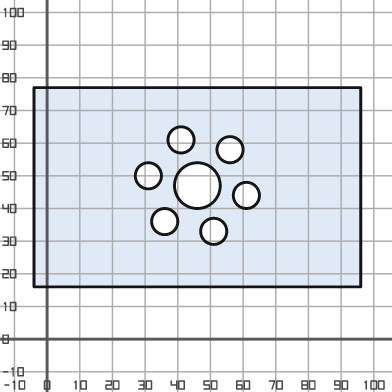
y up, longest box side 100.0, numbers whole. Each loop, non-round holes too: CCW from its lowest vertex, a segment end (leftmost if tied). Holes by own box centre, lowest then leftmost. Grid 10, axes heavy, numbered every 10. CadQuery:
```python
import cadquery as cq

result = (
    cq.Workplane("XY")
    .moveTo(-4.0, 16.0)
    .lineTo(96.0, 16.0)
    .lineTo(96.0, 77.0)
    .lineTo(-4.0, 77.0)
    .close()
    .moveTo(51.0, 33.0)
    .circle(4.0)
    .moveTo(36.0, 36.0)
    .circle(4.0)
    .moveTo(61.0, 44.0)
    .circle(4.0)
    .moveTo(46.0, 47.0)
    .circle(7.0)
    .moveTo(31.0, 50.0)
    .circle(4.0)
    .moveTo(56.0, 58.0)
    .circle(4.0)
    .moveTo(41.0, 61.0)
    .circle(4.0)
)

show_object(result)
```